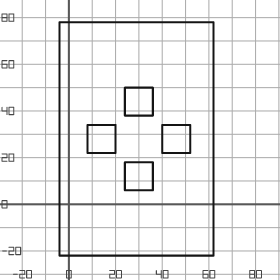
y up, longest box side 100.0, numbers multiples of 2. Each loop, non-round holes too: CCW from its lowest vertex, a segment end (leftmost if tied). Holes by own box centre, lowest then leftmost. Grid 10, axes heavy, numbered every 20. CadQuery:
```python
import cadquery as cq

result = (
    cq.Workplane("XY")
    .moveTo(-4.0, -22.0)
    .lineTo(62.0, -22.0)
    .lineTo(62.0, 78.0)
    .lineTo(-4.0, 78.0)
    .close()
    .moveTo(24.0, 6.0)
    .lineTo(36.0, 6.0)
    .lineTo(36.0, 18.0)
    .lineTo(24.0, 18.0)
    .close()
    .moveTo(8.0, 22.0)
    .lineTo(20.0, 22.0)
    .lineTo(20.0, 34.0)
    .lineTo(8.0, 34.0)
    .close()
    .moveTo(40.0, 22.0)
    .lineTo(52.0, 22.0)
    .lineTo(52.0, 34.0)
    .lineTo(40.0, 34.0)
    .close()
    .moveTo(24.0, 38.0)
    .lineTo(36.0, 38.0)
    .lineTo(36.0, 50.0)
    .lineTo(24.0, 50.0)
    .close()
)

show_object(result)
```